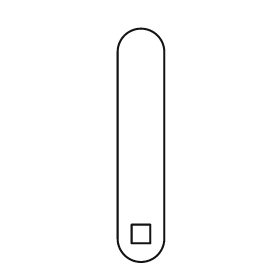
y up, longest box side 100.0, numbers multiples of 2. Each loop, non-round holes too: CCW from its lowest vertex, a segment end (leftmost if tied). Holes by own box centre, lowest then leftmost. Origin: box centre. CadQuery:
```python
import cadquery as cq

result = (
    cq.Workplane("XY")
    .moveTo(-10.0, -40.0)
    .threePointArc((0.0, -50.0), (10.0, -40.0))
    .lineTo(10.0, 40.0)
    .threePointArc((0.0, 50.0), (-10.0, 40.0))
    .close()
    .moveTo(-4.0, -42.0)
    .lineTo(4.0, -42.0)
    .lineTo(4.0, -34.0)
    .lineTo(-4.0, -34.0)
    .close()
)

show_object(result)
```